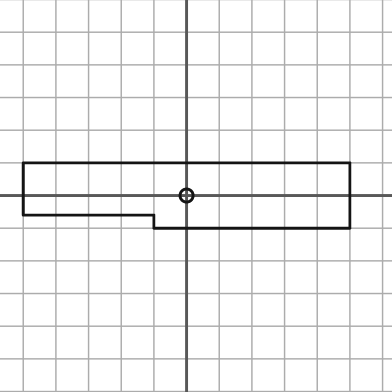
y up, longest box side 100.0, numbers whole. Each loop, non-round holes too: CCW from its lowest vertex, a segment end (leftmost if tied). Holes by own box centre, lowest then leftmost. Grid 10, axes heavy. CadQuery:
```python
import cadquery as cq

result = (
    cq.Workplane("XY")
    .moveTo(-10.0, -10.0)
    .lineTo(50.0, -10.0)
    .lineTo(50.0, 10.0)
    .lineTo(-50.0, 10.0)
    .lineTo(-50.0, -6.0)
    .lineTo(-10.0, -6.0)
    .close()
    .moveTo(0.0, 0.0)
    .circle(2.0)
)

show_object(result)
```